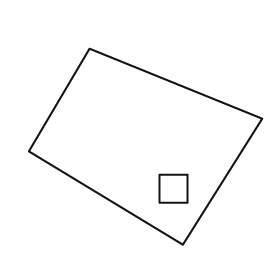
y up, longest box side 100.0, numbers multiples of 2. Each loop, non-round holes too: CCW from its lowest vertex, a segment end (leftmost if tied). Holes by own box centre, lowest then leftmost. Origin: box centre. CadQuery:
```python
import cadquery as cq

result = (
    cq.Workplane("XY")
    .moveTo(16.0, -42.0)
    .lineTo(50.0, 12.0)
    .lineTo(-24.0, 42.0)
    .lineTo(-50.0, -2.0)
    .close()
    .moveTo(6.0, -24.0)
    .lineTo(18.0, -24.0)
    .lineTo(18.0, -12.0)
    .lineTo(6.0, -12.0)
    .close()
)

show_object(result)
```